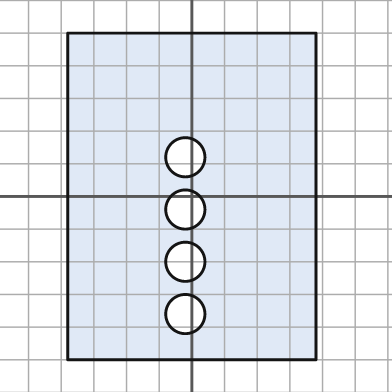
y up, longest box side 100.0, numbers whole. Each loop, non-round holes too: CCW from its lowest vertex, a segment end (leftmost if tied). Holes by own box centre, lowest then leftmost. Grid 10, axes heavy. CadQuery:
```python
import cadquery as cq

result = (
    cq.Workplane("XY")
    .moveTo(-38.0, -50.0)
    .lineTo(38.0, -50.0)
    .lineTo(38.0, 50.0)
    .lineTo(-38.0, 50.0)
    .close()
    .moveTo(-2.0, -36.0)
    .circle(6.0)
    .moveTo(-2.0, -20.0)
    .circle(6.0)
    .moveTo(-2.0, -4.0)
    .circle(6.0)
    .moveTo(-2.0, 12.0)
    .circle(6.0)
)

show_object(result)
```